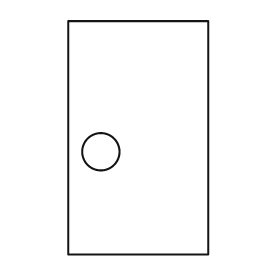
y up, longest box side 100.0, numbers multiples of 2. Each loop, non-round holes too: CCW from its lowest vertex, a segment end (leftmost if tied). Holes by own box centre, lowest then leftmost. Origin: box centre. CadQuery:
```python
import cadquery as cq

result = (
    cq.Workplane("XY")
    .moveTo(-30.0, -50.0)
    .lineTo(30.0, -50.0)
    .lineTo(30.0, 50.0)
    .lineTo(-30.0, 50.0)
    .close()
    .moveTo(-16.0, -6.0)
    .circle(8.0)
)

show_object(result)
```